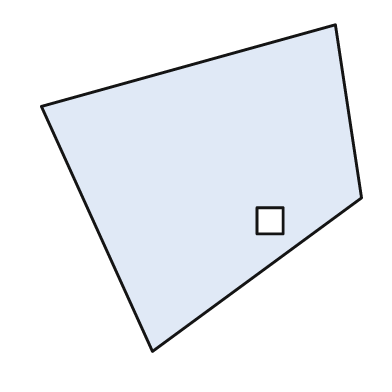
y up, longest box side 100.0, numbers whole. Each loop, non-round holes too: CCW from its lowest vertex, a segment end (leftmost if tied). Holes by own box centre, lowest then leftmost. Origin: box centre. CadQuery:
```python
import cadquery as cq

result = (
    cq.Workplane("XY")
    .moveTo(-15.0, -50.0)
    .lineTo(49.0, -3.0)
    .lineTo(41.0, 50.0)
    .lineTo(-49.0, 25.0)
    .close()
    .moveTo(17.0, -14.0)
    .lineTo(25.0, -14.0)
    .lineTo(25.0, -6.0)
    .lineTo(17.0, -6.0)
    .close()
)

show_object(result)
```